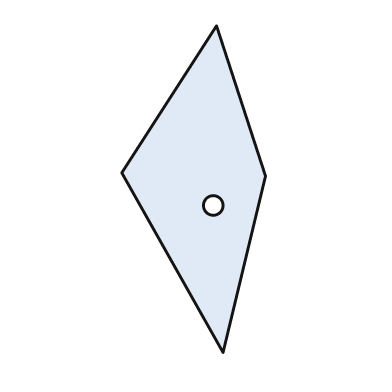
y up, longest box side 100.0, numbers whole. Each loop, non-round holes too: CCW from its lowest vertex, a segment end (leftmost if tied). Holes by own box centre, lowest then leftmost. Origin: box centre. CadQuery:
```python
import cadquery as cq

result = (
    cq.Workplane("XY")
    .moveTo(9.0, -50.0)
    .lineTo(22.0, 4.0)
    .lineTo(7.0, 50.0)
    .lineTo(-22.0, 5.0)
    .close()
    .moveTo(6.0, -5.0)
    .circle(3.0)
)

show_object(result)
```